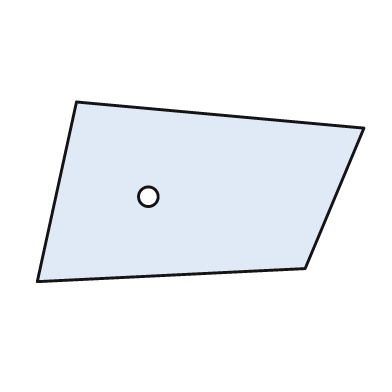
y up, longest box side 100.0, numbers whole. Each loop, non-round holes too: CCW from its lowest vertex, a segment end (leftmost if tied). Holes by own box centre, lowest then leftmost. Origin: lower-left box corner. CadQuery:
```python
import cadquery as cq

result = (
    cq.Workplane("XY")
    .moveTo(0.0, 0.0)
    .lineTo(82.0, 4.0)
    .lineTo(100.0, 47.0)
    .lineTo(12.0, 55.0)
    .close()
    .moveTo(34.0, 26.0)
    .circle(3.0)
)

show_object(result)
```